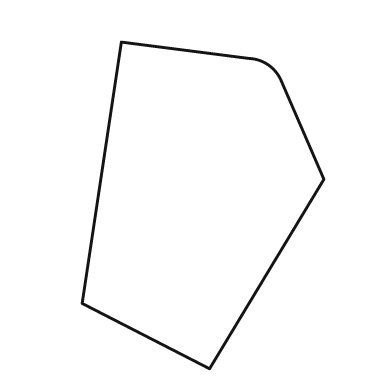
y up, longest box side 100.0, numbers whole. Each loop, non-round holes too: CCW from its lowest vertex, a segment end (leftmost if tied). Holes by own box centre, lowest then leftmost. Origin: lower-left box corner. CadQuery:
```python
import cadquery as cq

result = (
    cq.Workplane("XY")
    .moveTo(39.0, 0.0)
    .lineTo(74.0, 58.0)
    .lineTo(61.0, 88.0)
    .threePointArc((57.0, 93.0), (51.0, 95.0))
    .lineTo(12.0, 100.0)
    .lineTo(0.0, 20.0)
    .close()
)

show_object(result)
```